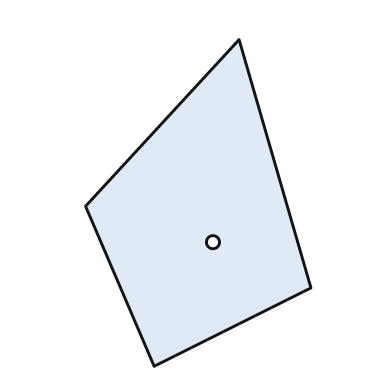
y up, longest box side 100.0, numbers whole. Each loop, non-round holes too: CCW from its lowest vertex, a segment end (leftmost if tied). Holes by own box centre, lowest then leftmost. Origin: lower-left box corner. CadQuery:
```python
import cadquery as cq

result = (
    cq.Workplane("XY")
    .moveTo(21.0, 0.0)
    .lineTo(69.0, 24.0)
    .lineTo(47.0, 100.0)
    .lineTo(0.0, 49.0)
    .close()
    .moveTo(39.0, 38.0)
    .circle(2.0)
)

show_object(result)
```